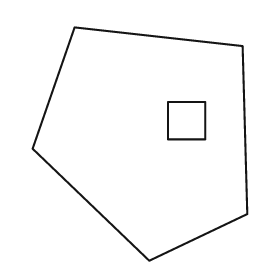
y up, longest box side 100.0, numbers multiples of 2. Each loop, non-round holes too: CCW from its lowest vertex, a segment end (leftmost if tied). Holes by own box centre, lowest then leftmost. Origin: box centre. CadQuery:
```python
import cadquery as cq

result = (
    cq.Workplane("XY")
    .moveTo(4.0, -50.0)
    .lineTo(46.0, -30.0)
    .lineTo(44.0, 42.0)
    .lineTo(-28.0, 50.0)
    .lineTo(-46.0, -2.0)
    .close()
    .moveTo(12.0, 2.0)
    .lineTo(28.0, 2.0)
    .lineTo(28.0, 18.0)
    .lineTo(12.0, 18.0)
    .close()
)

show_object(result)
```